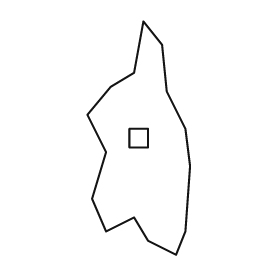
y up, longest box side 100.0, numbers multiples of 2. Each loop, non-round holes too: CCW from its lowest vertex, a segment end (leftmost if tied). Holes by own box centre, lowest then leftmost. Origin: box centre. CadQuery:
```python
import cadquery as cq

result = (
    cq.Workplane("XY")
    .moveTo(16.0, -50.0)
    .lineTo(20.0, -40.0)
    .lineTo(22.0, -12.0)
    .lineTo(20.0, 4.0)
    .lineTo(12.0, 20.0)
    .lineTo(10.0, 40.0)
    .lineTo(2.0, 50.0)
    .lineTo(-2.0, 28.0)
    .lineTo(-12.0, 22.0)
    .lineTo(-22.0, 10.0)
    .lineTo(-14.0, -6.0)
    .lineTo(-20.0, -26.0)
    .lineTo(-14.0, -40.0)
    .lineTo(-2.0, -34.0)
    .lineTo(4.0, -44.0)
    .close()
    .moveTo(-4.0, -4.0)
    .lineTo(4.0, -4.0)
    .lineTo(4.0, 4.0)
    .lineTo(-4.0, 4.0)
    .close()
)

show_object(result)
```